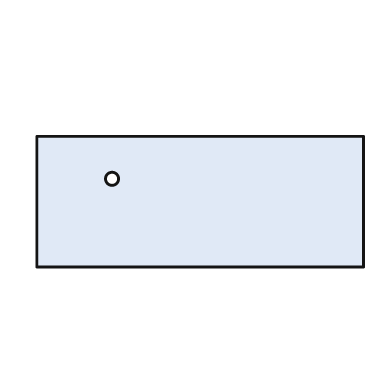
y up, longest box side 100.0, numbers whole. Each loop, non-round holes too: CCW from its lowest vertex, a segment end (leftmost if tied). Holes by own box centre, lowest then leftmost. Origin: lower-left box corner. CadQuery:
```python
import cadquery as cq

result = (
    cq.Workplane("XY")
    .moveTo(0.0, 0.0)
    .lineTo(100.0, 0.0)
    .lineTo(100.0, 40.0)
    .lineTo(0.0, 40.0)
    .close()
    .moveTo(23.0, 27.0)
    .circle(2.0)
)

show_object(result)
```